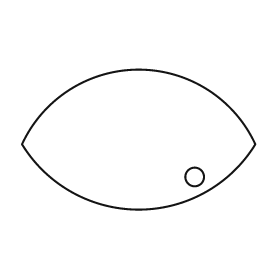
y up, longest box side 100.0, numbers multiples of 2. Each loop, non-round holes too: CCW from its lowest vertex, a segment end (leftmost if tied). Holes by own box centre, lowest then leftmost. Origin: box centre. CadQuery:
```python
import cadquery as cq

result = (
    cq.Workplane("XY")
    .moveTo(-50.0, -2.0)
    .threePointArc((0.0, -30.0), (50.0, -2.0))
    .threePointArc((0.0, 30.0), (-50.0, -2.0))
    .close()
    .moveTo(24.0, -16.0)
    .circle(4.0)
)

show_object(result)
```